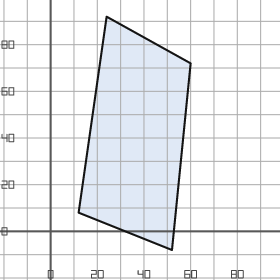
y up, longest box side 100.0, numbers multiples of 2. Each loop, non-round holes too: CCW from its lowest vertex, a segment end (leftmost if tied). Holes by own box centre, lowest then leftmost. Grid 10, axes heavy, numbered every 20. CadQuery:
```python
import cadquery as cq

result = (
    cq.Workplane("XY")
    .moveTo(52.0, -8.0)
    .lineTo(60.0, 72.0)
    .lineTo(24.0, 92.0)
    .lineTo(12.0, 8.0)
    .close()
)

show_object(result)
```